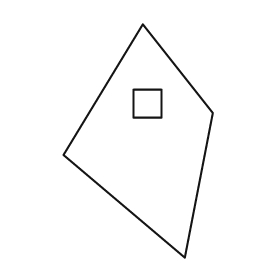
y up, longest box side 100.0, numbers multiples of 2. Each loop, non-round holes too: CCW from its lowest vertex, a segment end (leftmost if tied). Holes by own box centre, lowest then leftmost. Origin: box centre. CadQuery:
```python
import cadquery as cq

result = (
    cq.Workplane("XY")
    .moveTo(20.0, -50.0)
    .lineTo(32.0, 12.0)
    .lineTo(2.0, 50.0)
    .lineTo(-32.0, -6.0)
    .close()
    .moveTo(-2.0, 10.0)
    .lineTo(10.0, 10.0)
    .lineTo(10.0, 22.0)
    .lineTo(-2.0, 22.0)
    .close()
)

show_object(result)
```